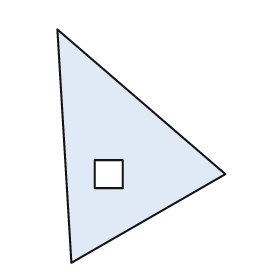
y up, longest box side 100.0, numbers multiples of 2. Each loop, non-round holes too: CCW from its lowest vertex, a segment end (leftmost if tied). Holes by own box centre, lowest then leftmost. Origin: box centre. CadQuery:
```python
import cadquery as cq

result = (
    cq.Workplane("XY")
    .moveTo(-30.0, -50.0)
    .lineTo(36.0, -12.0)
    .lineTo(-36.0, 50.0)
    .close()
    .moveTo(-20.0, -18.0)
    .lineTo(-8.0, -18.0)
    .lineTo(-8.0, -6.0)
    .lineTo(-20.0, -6.0)
    .close()
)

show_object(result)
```